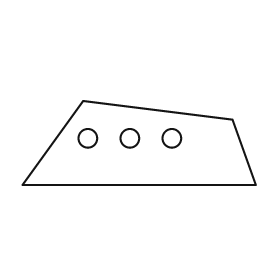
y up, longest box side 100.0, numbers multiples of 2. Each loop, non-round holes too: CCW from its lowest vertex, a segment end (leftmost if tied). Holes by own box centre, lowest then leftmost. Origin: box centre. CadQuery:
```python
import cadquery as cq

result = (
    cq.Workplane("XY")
    .moveTo(-50.0, -18.0)
    .lineTo(50.0, -18.0)
    .lineTo(40.0, 10.0)
    .lineTo(-24.0, 18.0)
    .close()
    .moveTo(-22.0, 2.0)
    .circle(4.0)
    .moveTo(-4.0, 2.0)
    .circle(4.0)
    .moveTo(14.0, 2.0)
    .circle(4.0)
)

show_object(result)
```